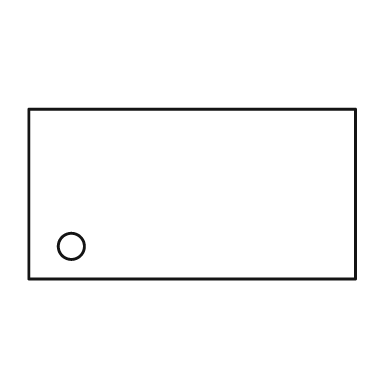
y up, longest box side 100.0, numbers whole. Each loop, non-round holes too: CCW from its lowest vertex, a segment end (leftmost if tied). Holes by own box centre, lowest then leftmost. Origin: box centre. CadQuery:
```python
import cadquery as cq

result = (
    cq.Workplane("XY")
    .moveTo(-50.0, -26.0)
    .lineTo(50.0, -26.0)
    .lineTo(50.0, 26.0)
    .lineTo(-50.0, 26.0)
    .close()
    .moveTo(-37.0, -16.0)
    .circle(4.0)
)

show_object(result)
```